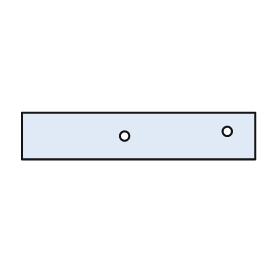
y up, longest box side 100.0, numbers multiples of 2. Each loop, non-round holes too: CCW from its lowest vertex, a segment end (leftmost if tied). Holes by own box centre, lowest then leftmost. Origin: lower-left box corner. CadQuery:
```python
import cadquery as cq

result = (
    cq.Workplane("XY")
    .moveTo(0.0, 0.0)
    .lineTo(100.0, 0.0)
    .lineTo(100.0, 20.0)
    .lineTo(0.0, 20.0)
    .close()
    .moveTo(44.0, 10.0)
    .circle(2.0)
    .moveTo(88.0, 12.0)
    .circle(2.0)
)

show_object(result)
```